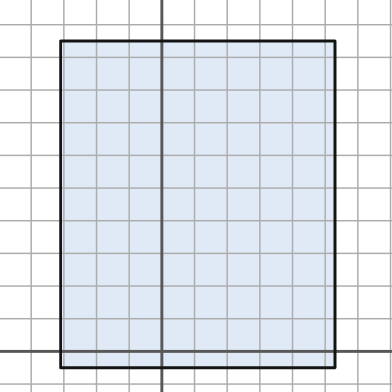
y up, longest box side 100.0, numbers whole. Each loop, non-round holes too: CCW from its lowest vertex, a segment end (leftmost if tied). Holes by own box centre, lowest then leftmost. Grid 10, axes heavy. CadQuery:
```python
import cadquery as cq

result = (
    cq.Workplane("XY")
    .moveTo(-31.0, -5.0)
    .lineTo(53.0, -5.0)
    .lineTo(53.0, 95.0)
    .lineTo(-31.0, 95.0)
    .close()
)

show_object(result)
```